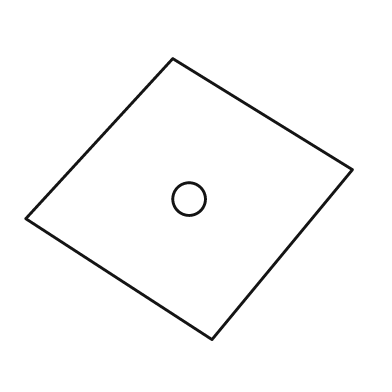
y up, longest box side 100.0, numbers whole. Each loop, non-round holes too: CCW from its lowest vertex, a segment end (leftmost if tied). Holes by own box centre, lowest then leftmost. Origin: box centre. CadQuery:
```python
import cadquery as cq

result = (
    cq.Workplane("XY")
    .moveTo(7.0, -43.0)
    .lineTo(50.0, 9.0)
    .lineTo(-5.0, 43.0)
    .lineTo(-50.0, -6.0)
    .close()
    .moveTo(0.0, 0.0)
    .circle(5.0)
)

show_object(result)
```